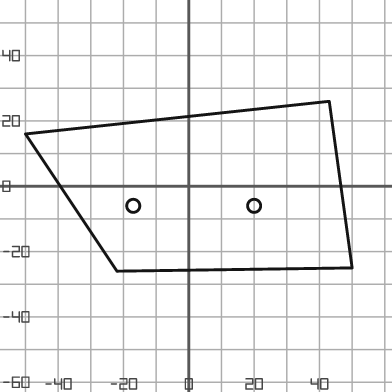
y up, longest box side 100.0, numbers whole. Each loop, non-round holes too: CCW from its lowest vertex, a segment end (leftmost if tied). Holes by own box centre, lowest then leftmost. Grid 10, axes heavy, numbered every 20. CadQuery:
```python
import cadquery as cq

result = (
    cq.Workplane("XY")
    .moveTo(-22.0, -26.0)
    .lineTo(50.0, -25.0)
    .lineTo(43.0, 26.0)
    .lineTo(-50.0, 16.0)
    .close()
    .moveTo(-17.0, -6.0)
    .circle(2.0)
    .moveTo(20.0, -6.0)
    .circle(2.0)
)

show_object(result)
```